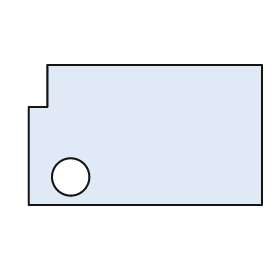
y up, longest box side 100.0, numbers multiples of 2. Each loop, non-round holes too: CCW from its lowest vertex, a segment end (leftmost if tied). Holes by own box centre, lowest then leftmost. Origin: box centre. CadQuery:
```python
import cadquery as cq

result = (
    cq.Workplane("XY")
    .moveTo(-50.0, -30.0)
    .lineTo(50.0, -30.0)
    .lineTo(50.0, 30.0)
    .lineTo(-42.0, 30.0)
    .lineTo(-42.0, 12.0)
    .lineTo(-50.0, 12.0)
    .close()
    .moveTo(-32.0, -18.0)
    .circle(8.0)
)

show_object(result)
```